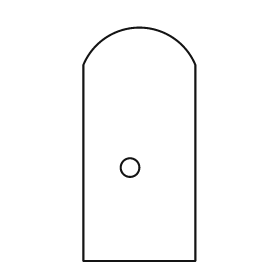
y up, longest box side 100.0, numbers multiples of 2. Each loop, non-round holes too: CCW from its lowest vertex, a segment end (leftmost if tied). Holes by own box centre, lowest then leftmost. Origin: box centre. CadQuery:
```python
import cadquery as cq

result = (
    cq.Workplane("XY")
    .moveTo(-24.0, -50.0)
    .lineTo(24.0, -50.0)
    .lineTo(24.0, 34.0)
    .threePointArc((0.0, 50.0), (-24.0, 34.0))
    .close()
    .moveTo(-4.0, -10.0)
    .circle(4.0)
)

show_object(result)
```